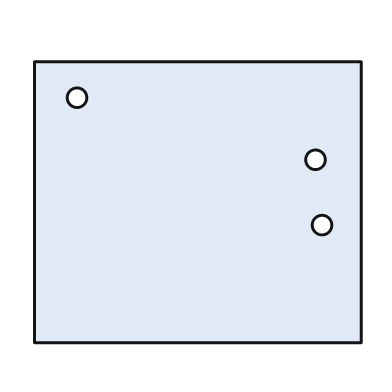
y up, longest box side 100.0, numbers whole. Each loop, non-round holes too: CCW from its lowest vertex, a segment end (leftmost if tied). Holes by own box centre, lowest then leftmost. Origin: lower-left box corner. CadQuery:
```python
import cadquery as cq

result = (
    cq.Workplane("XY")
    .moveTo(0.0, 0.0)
    .lineTo(100.0, 0.0)
    .lineTo(100.0, 86.0)
    .lineTo(0.0, 86.0)
    .close()
    .moveTo(88.0, 36.0)
    .circle(3.0)
    .moveTo(86.0, 56.0)
    .circle(3.0)
    .moveTo(13.0, 75.0)
    .circle(3.0)
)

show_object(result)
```